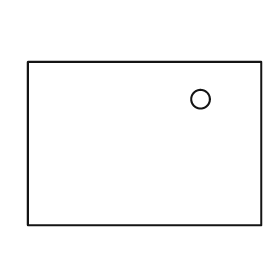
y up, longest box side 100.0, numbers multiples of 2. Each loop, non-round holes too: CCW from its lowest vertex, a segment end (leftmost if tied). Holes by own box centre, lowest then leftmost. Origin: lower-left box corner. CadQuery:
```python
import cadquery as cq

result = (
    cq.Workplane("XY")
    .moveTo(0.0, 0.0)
    .lineTo(100.0, 0.0)
    .lineTo(100.0, 70.0)
    .lineTo(0.0, 70.0)
    .close()
    .moveTo(74.0, 54.0)
    .circle(4.0)
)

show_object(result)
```